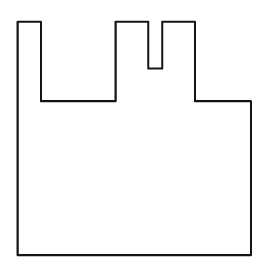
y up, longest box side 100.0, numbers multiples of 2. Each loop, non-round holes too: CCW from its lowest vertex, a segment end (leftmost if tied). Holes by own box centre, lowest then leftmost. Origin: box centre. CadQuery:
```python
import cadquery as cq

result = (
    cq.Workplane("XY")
    .moveTo(-50.0, -50.0)
    .lineTo(50.0, -50.0)
    .lineTo(50.0, 16.0)
    .lineTo(26.0, 16.0)
    .lineTo(26.0, 50.0)
    .lineTo(12.0, 50.0)
    .lineTo(12.0, 30.0)
    .lineTo(6.0, 30.0)
    .lineTo(6.0, 50.0)
    .lineTo(-8.0, 50.0)
    .lineTo(-8.0, 16.0)
    .lineTo(-40.0, 16.0)
    .lineTo(-40.0, 50.0)
    .lineTo(-50.0, 50.0)
    .close()
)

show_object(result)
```